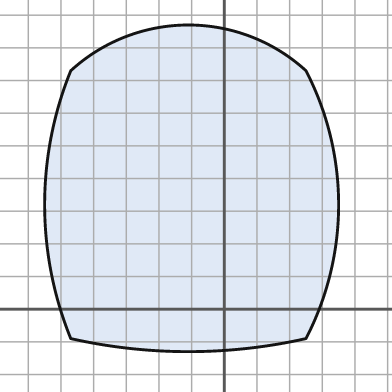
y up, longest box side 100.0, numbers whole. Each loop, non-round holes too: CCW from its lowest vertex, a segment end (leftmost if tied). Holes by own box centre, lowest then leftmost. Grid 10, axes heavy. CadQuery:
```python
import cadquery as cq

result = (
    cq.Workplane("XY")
    .moveTo(-47.0, -9.0)
    .threePointArc((-11.0, -13.0), (25.0, -9.0))
    .threePointArc((35.0, 32.0), (25.0, 73.0))
    .threePointArc((-11.0, 87.0), (-47.0, 73.0))
    .threePointArc((-55.0, 32.0), (-47.0, -9.0))
    .close()
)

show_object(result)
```